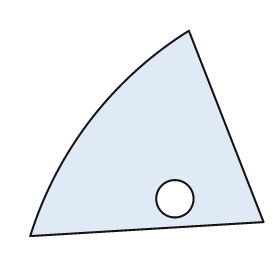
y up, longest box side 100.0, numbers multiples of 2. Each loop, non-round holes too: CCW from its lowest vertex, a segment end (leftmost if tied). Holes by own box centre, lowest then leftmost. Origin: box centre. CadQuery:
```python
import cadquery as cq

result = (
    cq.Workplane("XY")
    .moveTo(-50.0, -44.0)
    .lineTo(50.0, -38.0)
    .lineTo(18.0, 44.0)
    .threePointArc((-24.0, 6.0), (-50.0, -44.0))
    .close()
    .moveTo(12.0, -28.0)
    .circle(8.0)
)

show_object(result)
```